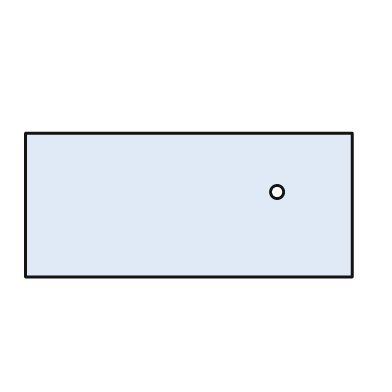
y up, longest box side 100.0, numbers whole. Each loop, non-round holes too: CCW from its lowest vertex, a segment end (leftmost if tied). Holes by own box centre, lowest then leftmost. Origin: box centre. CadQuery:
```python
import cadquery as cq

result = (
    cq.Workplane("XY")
    .moveTo(-50.0, -22.0)
    .lineTo(50.0, -22.0)
    .lineTo(50.0, 22.0)
    .lineTo(-50.0, 22.0)
    .close()
    .moveTo(27.0, 4.0)
    .circle(2.0)
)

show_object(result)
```